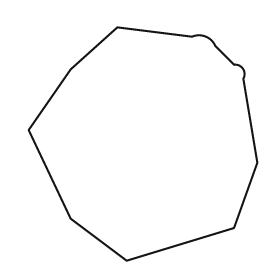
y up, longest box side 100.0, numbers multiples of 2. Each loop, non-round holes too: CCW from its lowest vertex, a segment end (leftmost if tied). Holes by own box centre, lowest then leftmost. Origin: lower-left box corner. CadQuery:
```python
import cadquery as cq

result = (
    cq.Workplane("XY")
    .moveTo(42.0, 0.0)
    .lineTo(88.0, 14.0)
    .lineTo(98.0, 42.0)
    .lineTo(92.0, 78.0)
    .threePointArc((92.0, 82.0), (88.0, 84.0))
    .lineTo(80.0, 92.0)
    .threePointArc((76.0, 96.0), (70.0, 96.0))
    .lineTo(38.0, 100.0)
    .lineTo(18.0, 82.0)
    .lineTo(0.0, 56.0)
    .lineTo(18.0, 18.0)
    .close()
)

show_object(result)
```